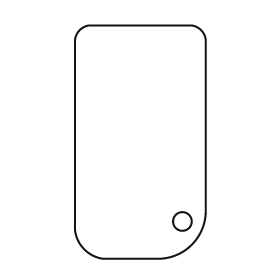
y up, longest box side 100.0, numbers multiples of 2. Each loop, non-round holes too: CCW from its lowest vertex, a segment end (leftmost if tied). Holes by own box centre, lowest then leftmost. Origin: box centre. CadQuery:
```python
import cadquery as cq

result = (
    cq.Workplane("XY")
    .moveTo(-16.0, -50.0)
    .lineTo(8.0, -50.0)
    .threePointArc((22.0, -44.0), (28.0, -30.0))
    .lineTo(28.0, 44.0)
    .threePointArc((26.0, 48.0), (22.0, 50.0))
    .lineTo(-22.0, 50.0)
    .threePointArc((-26.0, 48.0), (-28.0, 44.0))
    .lineTo(-28.0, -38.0)
    .threePointArc((-24.0, -46.0), (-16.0, -50.0))
    .close()
    .moveTo(18.0, -34.0)
    .circle(4.0)
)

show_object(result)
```